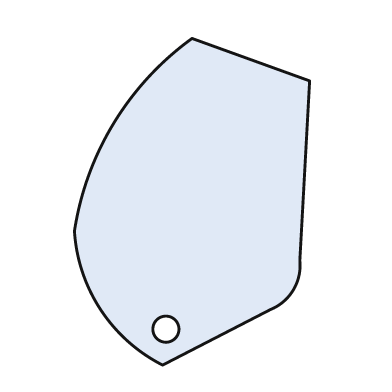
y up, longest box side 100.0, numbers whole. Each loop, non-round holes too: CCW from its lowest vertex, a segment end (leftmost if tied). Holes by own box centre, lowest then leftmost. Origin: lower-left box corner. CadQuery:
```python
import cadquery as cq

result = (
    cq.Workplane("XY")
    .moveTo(27.0, 0.0)
    .lineTo(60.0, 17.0)
    .threePointArc((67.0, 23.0), (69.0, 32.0))
    .lineTo(72.0, 87.0)
    .lineTo(36.0, 100.0)
    .threePointArc((12.0, 74.0), (0.0, 41.0))
    .threePointArc((8.0, 17.0), (27.0, 0.0))
    .close()
    .moveTo(28.0, 11.0)
    .circle(4.0)
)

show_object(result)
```